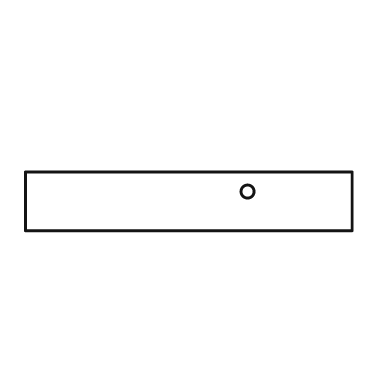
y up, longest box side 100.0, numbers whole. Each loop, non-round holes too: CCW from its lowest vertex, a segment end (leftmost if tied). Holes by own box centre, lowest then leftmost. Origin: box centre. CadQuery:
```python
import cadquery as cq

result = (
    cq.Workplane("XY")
    .moveTo(-50.0, -9.0)
    .lineTo(50.0, -9.0)
    .lineTo(50.0, 9.0)
    .lineTo(-50.0, 9.0)
    .close()
    .moveTo(18.0, 3.0)
    .circle(2.0)
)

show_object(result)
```